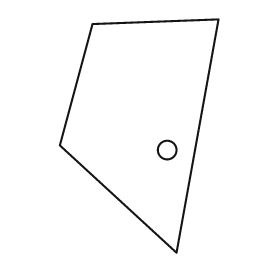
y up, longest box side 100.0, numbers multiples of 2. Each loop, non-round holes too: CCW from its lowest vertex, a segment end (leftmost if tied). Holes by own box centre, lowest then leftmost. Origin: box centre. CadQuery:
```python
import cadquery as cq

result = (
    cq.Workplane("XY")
    .moveTo(16.0, -50.0)
    .lineTo(34.0, 50.0)
    .lineTo(-20.0, 48.0)
    .lineTo(-34.0, -4.0)
    .close()
    .moveTo(12.0, -6.0)
    .circle(4.0)
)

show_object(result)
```